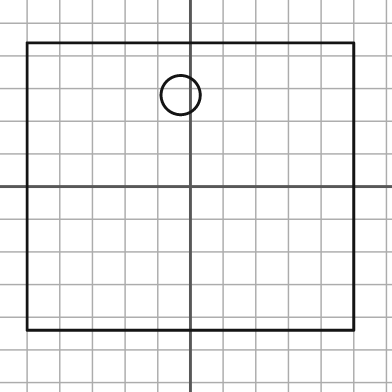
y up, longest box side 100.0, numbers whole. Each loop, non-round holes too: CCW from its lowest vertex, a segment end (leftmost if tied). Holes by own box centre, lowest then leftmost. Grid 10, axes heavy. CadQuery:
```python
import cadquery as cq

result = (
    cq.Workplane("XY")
    .moveTo(-50.0, -44.0)
    .lineTo(50.0, -44.0)
    .lineTo(50.0, 44.0)
    .lineTo(-50.0, 44.0)
    .close()
    .moveTo(-3.0, 28.0)
    .circle(6.0)
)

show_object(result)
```